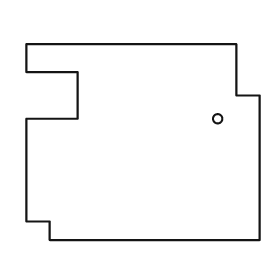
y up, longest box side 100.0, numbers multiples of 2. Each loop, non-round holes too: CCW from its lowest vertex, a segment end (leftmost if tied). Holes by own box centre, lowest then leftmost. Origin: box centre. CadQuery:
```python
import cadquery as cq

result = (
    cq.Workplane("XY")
    .moveTo(-40.0, -42.0)
    .lineTo(50.0, -42.0)
    .lineTo(50.0, 20.0)
    .lineTo(40.0, 20.0)
    .lineTo(40.0, 42.0)
    .lineTo(-50.0, 42.0)
    .lineTo(-50.0, 30.0)
    .lineTo(-28.0, 30.0)
    .lineTo(-28.0, 10.0)
    .lineTo(-50.0, 10.0)
    .lineTo(-50.0, -34.0)
    .lineTo(-40.0, -34.0)
    .close()
    .moveTo(32.0, 10.0)
    .circle(2.0)
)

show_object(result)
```